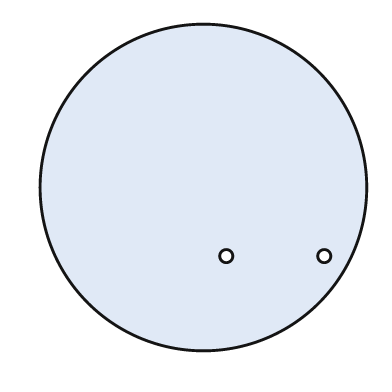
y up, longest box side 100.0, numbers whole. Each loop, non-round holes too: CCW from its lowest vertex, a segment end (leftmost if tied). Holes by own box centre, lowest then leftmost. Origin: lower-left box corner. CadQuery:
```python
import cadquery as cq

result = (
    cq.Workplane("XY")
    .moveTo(50.0, 50.0)
    .circle(50.0)
    .moveTo(57.0, 29.0)
    .circle(2.0)
    .moveTo(87.0, 29.0)
    .circle(2.0)
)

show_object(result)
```